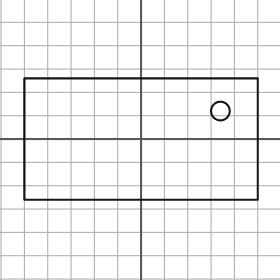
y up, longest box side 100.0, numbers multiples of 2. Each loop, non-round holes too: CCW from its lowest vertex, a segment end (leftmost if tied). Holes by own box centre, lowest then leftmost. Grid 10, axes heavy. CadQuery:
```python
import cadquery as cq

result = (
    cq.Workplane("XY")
    .moveTo(-50.0, -26.0)
    .lineTo(50.0, -26.0)
    .lineTo(50.0, 26.0)
    .lineTo(-50.0, 26.0)
    .close()
    .moveTo(34.0, 12.0)
    .circle(4.0)
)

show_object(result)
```